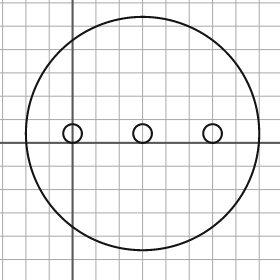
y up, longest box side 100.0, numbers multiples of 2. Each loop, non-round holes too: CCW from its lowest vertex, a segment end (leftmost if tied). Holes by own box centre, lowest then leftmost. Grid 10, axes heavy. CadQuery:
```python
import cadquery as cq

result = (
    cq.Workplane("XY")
    .moveTo(30.0, 4.0)
    .circle(50.0)
    .moveTo(0.0, 4.0)
    .circle(4.0)
    .moveTo(30.0, 4.0)
    .circle(4.0)
    .moveTo(60.0, 4.0)
    .circle(4.0)
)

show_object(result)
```